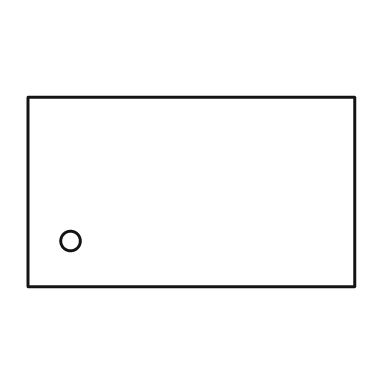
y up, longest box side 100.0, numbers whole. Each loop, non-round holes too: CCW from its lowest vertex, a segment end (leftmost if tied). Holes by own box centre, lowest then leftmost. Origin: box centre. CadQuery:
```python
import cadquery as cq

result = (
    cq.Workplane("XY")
    .moveTo(-50.0, -29.0)
    .lineTo(50.0, -29.0)
    .lineTo(50.0, 29.0)
    .lineTo(-50.0, 29.0)
    .close()
    .moveTo(-37.0, -15.0)
    .circle(3.0)
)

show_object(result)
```